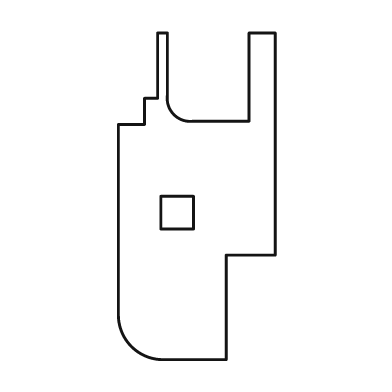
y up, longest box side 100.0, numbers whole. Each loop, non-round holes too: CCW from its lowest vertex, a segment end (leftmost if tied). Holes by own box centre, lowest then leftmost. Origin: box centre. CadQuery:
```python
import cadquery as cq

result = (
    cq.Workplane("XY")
    .moveTo(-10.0, -50.0)
    .lineTo(9.0, -50.0)
    .lineTo(9.0, -18.0)
    .lineTo(24.0, -18.0)
    .lineTo(24.0, 50.0)
    .lineTo(16.0, 50.0)
    .lineTo(16.0, 23.0)
    .lineTo(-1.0, 23.0)
    .threePointArc((-7.0, 25.0), (-9.0, 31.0))
    .lineTo(-9.0, 50.0)
    .lineTo(-12.0, 50.0)
    .lineTo(-12.0, 30.0)
    .lineTo(-16.0, 30.0)
    .lineTo(-16.0, 22.0)
    .lineTo(-24.0, 22.0)
    .lineTo(-24.0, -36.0)
    .threePointArc((-20.0, -46.0), (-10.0, -50.0))
    .close()
    .moveTo(-11.0, -10.0)
    .lineTo(-1.0, -10.0)
    .lineTo(-1.0, 0.0)
    .lineTo(-11.0, 0.0)
    .close()
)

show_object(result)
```